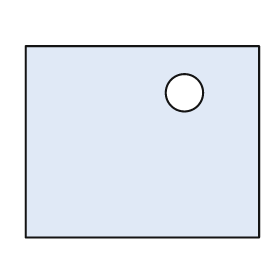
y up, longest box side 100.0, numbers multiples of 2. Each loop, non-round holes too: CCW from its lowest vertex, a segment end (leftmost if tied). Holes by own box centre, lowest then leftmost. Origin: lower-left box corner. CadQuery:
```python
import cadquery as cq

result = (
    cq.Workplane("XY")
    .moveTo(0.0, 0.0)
    .lineTo(100.0, 0.0)
    .lineTo(100.0, 82.0)
    .lineTo(0.0, 82.0)
    .close()
    .moveTo(68.0, 62.0)
    .circle(8.0)
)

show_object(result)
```